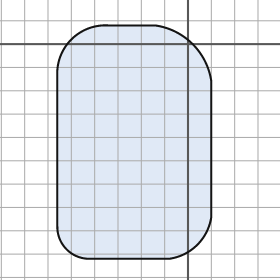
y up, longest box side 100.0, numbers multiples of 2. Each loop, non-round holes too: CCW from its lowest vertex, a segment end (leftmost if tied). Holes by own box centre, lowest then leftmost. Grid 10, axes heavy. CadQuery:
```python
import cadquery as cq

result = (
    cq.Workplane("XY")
    .moveTo(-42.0, -92.0)
    .lineTo(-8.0, -92.0)
    .threePointArc((4.0, -86.0), (10.0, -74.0))
    .lineTo(10.0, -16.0)
    .threePointArc((2.0, 0.0), (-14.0, 8.0))
    .lineTo(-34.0, 8.0)
    .threePointArc((-50.0, 2.0), (-56.0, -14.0))
    .lineTo(-56.0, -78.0)
    .threePointArc((-52.0, -88.0), (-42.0, -92.0))
    .close()
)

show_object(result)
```